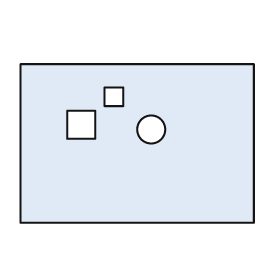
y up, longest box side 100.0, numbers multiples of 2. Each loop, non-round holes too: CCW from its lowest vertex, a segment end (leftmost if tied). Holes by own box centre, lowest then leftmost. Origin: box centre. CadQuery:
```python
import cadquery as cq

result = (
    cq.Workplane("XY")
    .moveTo(-50.0, -34.0)
    .lineTo(50.0, -34.0)
    .lineTo(50.0, 34.0)
    .lineTo(-50.0, 34.0)
    .close()
    .moveTo(6.0, 6.0)
    .circle(6.0)
    .moveTo(-30.0, 2.0)
    .lineTo(-18.0, 2.0)
    .lineTo(-18.0, 14.0)
    .lineTo(-30.0, 14.0)
    .close()
    .moveTo(-14.0, 16.0)
    .lineTo(-6.0, 16.0)
    .lineTo(-6.0, 24.0)
    .lineTo(-14.0, 24.0)
    .close()
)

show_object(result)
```